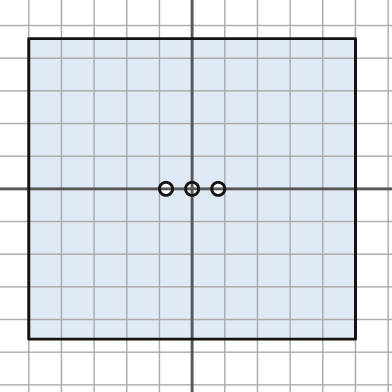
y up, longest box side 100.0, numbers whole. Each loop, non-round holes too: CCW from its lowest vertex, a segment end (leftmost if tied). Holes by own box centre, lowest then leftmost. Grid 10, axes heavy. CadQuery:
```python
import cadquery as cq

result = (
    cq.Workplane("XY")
    .moveTo(-50.0, -46.0)
    .lineTo(50.0, -46.0)
    .lineTo(50.0, 46.0)
    .lineTo(-50.0, 46.0)
    .close()
    .moveTo(-8.0, 0.0)
    .circle(2.0)
    .moveTo(0.0, 0.0)
    .circle(2.0)
    .moveTo(8.0, 0.0)
    .circle(2.0)
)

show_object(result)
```